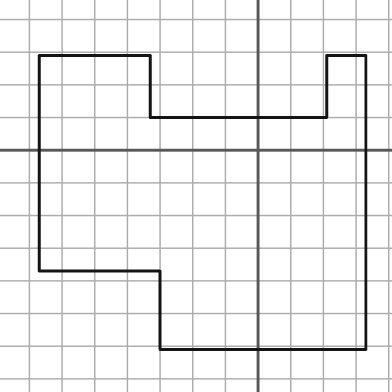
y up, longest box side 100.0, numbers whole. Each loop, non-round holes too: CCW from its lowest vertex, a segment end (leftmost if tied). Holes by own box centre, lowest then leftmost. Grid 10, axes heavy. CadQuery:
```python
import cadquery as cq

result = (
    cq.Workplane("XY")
    .moveTo(-30.0, -61.0)
    .lineTo(33.0, -61.0)
    .lineTo(33.0, 29.0)
    .lineTo(21.0, 29.0)
    .lineTo(21.0, 10.0)
    .lineTo(-33.0, 10.0)
    .lineTo(-33.0, 29.0)
    .lineTo(-67.0, 29.0)
    .lineTo(-67.0, -37.0)
    .lineTo(-30.0, -37.0)
    .close()
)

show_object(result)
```